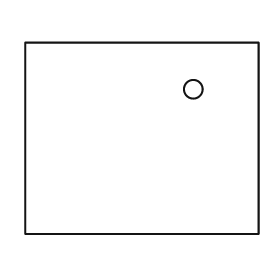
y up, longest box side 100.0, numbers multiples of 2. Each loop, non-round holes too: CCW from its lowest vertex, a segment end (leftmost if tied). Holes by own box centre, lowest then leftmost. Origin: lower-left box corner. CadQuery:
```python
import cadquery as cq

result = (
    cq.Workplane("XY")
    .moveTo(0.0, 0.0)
    .lineTo(100.0, 0.0)
    .lineTo(100.0, 82.0)
    .lineTo(0.0, 82.0)
    .close()
    .moveTo(72.0, 62.0)
    .circle(4.0)
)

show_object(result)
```